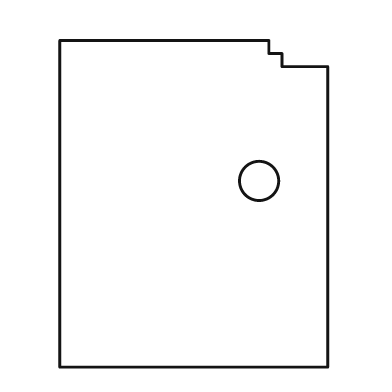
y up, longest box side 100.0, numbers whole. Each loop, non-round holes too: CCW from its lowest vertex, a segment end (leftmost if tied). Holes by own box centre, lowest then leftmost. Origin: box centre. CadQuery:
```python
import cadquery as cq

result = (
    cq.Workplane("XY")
    .moveTo(-41.0, -50.0)
    .lineTo(41.0, -50.0)
    .lineTo(41.0, 42.0)
    .lineTo(27.0, 42.0)
    .lineTo(27.0, 46.0)
    .lineTo(23.0, 46.0)
    .lineTo(23.0, 50.0)
    .lineTo(-41.0, 50.0)
    .close()
    .moveTo(20.0, 7.0)
    .circle(6.0)
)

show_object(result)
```